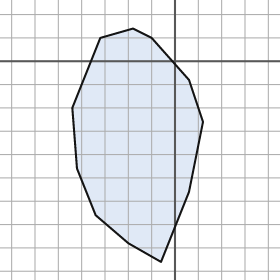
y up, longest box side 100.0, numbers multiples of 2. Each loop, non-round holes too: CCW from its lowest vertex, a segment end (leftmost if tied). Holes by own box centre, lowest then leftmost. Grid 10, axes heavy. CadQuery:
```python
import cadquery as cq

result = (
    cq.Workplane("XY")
    .moveTo(-6.0, -86.0)
    .lineTo(6.0, -56.0)
    .lineTo(12.0, -26.0)
    .lineTo(6.0, -8.0)
    .lineTo(-10.0, 10.0)
    .lineTo(-18.0, 14.0)
    .lineTo(-32.0, 10.0)
    .lineTo(-44.0, -20.0)
    .lineTo(-42.0, -46.0)
    .lineTo(-34.0, -66.0)
    .lineTo(-20.0, -78.0)
    .close()
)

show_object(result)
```